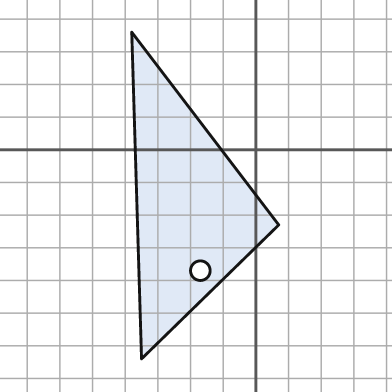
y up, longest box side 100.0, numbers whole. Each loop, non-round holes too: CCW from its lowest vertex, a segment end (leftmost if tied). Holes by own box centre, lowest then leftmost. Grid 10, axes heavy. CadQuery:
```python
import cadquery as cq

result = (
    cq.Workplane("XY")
    .moveTo(-35.0, -64.0)
    .lineTo(7.0, -23.0)
    .lineTo(-38.0, 36.0)
    .close()
    .moveTo(-17.0, -37.0)
    .circle(3.0)
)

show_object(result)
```